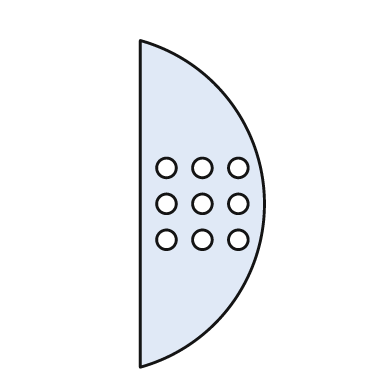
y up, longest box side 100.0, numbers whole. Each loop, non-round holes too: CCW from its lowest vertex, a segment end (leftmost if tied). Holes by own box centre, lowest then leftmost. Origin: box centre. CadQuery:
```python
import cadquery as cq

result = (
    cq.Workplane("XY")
    .moveTo(-19.0, -50.0)
    .threePointArc((19.0, 0.0), (-19.0, 50.0))
    .close()
    .moveTo(-11.0, -11.0)
    .circle(3.0)
    .moveTo(0.0, -11.0)
    .circle(3.0)
    .moveTo(11.0, -11.0)
    .circle(3.0)
    .moveTo(-11.0, 0.0)
    .circle(3.0)
    .moveTo(0.0, 0.0)
    .circle(3.0)
    .moveTo(11.0, 0.0)
    .circle(3.0)
    .moveTo(-11.0, 11.0)
    .circle(3.0)
    .moveTo(0.0, 11.0)
    .circle(3.0)
    .moveTo(11.0, 11.0)
    .circle(3.0)
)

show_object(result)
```